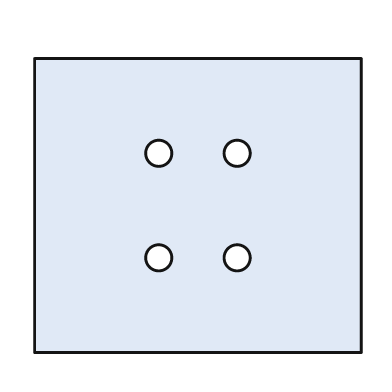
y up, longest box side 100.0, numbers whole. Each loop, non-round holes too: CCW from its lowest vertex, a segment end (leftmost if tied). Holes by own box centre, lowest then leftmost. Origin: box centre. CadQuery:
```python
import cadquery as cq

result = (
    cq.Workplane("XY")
    .moveTo(-50.0, -45.0)
    .lineTo(50.0, -45.0)
    .lineTo(50.0, 45.0)
    .lineTo(-50.0, 45.0)
    .close()
    .moveTo(-12.0, -16.0)
    .circle(4.0)
    .moveTo(12.0, -16.0)
    .circle(4.0)
    .moveTo(-12.0, 16.0)
    .circle(4.0)
    .moveTo(12.0, 16.0)
    .circle(4.0)
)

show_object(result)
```